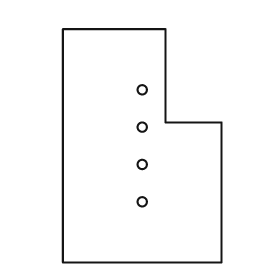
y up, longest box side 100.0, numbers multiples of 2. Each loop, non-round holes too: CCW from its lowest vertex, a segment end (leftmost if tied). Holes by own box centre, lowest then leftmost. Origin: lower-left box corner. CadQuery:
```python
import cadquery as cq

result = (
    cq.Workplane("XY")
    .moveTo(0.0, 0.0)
    .lineTo(68.0, 0.0)
    .lineTo(68.0, 60.0)
    .lineTo(44.0, 60.0)
    .lineTo(44.0, 100.0)
    .lineTo(0.0, 100.0)
    .close()
    .moveTo(34.0, 26.0)
    .circle(2.0)
    .moveTo(34.0, 42.0)
    .circle(2.0)
    .moveTo(34.0, 58.0)
    .circle(2.0)
    .moveTo(34.0, 74.0)
    .circle(2.0)
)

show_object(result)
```